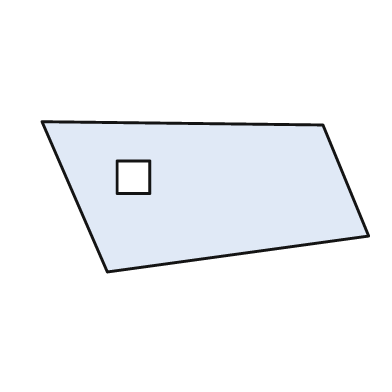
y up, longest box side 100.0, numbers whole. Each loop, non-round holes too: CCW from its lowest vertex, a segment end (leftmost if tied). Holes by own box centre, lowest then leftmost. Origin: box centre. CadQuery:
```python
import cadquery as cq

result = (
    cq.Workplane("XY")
    .moveTo(-30.0, -23.0)
    .lineTo(50.0, -12.0)
    .lineTo(36.0, 22.0)
    .lineTo(-50.0, 23.0)
    .close()
    .moveTo(-27.0, 1.0)
    .lineTo(-17.0, 1.0)
    .lineTo(-17.0, 11.0)
    .lineTo(-27.0, 11.0)
    .close()
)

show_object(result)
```